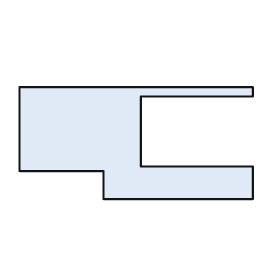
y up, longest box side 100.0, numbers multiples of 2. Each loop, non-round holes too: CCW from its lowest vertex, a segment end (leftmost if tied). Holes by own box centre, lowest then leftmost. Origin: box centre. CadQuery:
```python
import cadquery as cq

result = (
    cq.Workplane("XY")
    .moveTo(-14.0, -24.0)
    .lineTo(50.0, -24.0)
    .lineTo(50.0, -10.0)
    .lineTo(2.0, -10.0)
    .lineTo(2.0, 20.0)
    .lineTo(50.0, 20.0)
    .lineTo(50.0, 24.0)
    .lineTo(-50.0, 24.0)
    .lineTo(-50.0, -12.0)
    .lineTo(-14.0, -12.0)
    .close()
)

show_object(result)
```